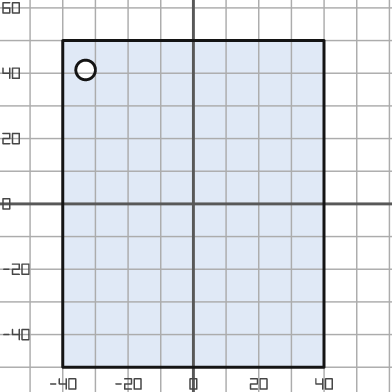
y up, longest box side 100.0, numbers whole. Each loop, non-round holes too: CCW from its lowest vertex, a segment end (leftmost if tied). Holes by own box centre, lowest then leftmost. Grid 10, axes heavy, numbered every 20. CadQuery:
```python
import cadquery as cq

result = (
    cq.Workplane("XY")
    .moveTo(-40.0, -50.0)
    .lineTo(40.0, -50.0)
    .lineTo(40.0, 50.0)
    .lineTo(-40.0, 50.0)
    .close()
    .moveTo(-33.0, 41.0)
    .circle(3.0)
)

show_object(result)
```